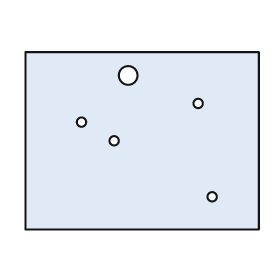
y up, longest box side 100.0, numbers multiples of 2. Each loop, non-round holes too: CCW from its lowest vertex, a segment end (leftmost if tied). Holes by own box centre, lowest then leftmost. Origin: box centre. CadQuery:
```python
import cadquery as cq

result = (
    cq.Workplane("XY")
    .moveTo(-50.0, -38.0)
    .lineTo(50.0, -38.0)
    .lineTo(50.0, 38.0)
    .lineTo(-50.0, 38.0)
    .close()
    .moveTo(30.0, -24.0)
    .circle(2.0)
    .moveTo(-12.0, 0.0)
    .circle(2.0)
    .moveTo(-26.0, 8.0)
    .circle(2.0)
    .moveTo(24.0, 16.0)
    .circle(2.0)
    .moveTo(-6.0, 28.0)
    .circle(4.0)
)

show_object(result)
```